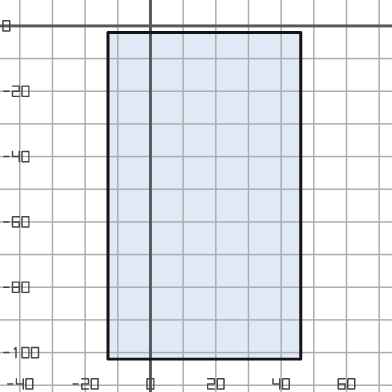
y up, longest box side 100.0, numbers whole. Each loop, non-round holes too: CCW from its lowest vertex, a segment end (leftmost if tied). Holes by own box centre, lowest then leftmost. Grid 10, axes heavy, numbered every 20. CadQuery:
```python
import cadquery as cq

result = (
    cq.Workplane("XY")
    .moveTo(-13.0, -102.0)
    .lineTo(46.0, -102.0)
    .lineTo(46.0, -2.0)
    .lineTo(-13.0, -2.0)
    .close()
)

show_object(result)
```